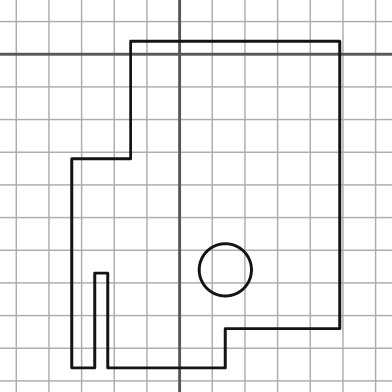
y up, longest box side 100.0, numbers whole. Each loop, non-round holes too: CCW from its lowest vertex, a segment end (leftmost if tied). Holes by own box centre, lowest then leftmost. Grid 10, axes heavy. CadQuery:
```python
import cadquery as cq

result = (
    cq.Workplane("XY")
    .moveTo(-33.0, -96.0)
    .lineTo(-26.0, -96.0)
    .lineTo(-26.0, -67.0)
    .lineTo(-22.0, -67.0)
    .lineTo(-22.0, -96.0)
    .lineTo(14.0, -96.0)
    .lineTo(14.0, -84.0)
    .lineTo(49.0, -84.0)
    .lineTo(49.0, 4.0)
    .lineTo(-15.0, 4.0)
    .lineTo(-15.0, -32.0)
    .lineTo(-33.0, -32.0)
    .close()
    .moveTo(14.0, -66.0)
    .circle(8.0)
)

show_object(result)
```